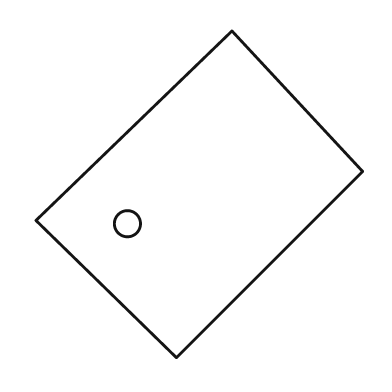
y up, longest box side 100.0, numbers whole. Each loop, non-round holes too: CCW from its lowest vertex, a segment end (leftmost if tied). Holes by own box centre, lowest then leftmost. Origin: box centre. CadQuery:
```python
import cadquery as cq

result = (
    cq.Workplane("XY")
    .moveTo(-7.0, -50.0)
    .lineTo(50.0, 7.0)
    .lineTo(10.0, 50.0)
    .lineTo(-50.0, -8.0)
    .close()
    .moveTo(-22.0, -9.0)
    .circle(4.0)
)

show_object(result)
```